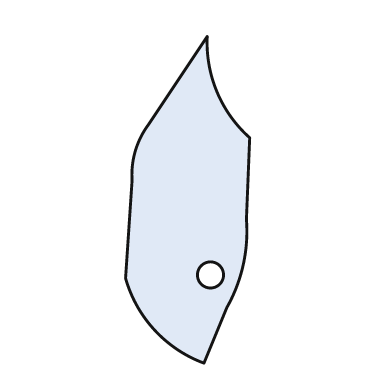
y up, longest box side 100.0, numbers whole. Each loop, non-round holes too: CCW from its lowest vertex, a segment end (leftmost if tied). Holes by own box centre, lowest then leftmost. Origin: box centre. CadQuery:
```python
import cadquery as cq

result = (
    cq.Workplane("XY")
    .moveTo(5.0, -50.0)
    .lineTo(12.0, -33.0)
    .threePointArc((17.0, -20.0), (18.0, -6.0))
    .lineTo(19.0, 19.0)
    .threePointArc((9.0, 33.0), (6.0, 50.0))
    .lineTo(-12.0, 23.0)
    .threePointArc((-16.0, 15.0), (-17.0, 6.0))
    .lineTo(-19.0, -24.0)
    .threePointArc((-10.0, -40.0), (5.0, -50.0))
    .close()
    .moveTo(7.0, -23.0)
    .circle(4.0)
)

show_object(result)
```